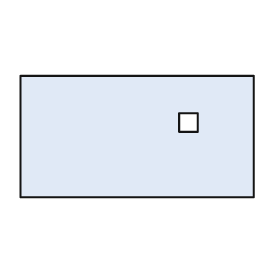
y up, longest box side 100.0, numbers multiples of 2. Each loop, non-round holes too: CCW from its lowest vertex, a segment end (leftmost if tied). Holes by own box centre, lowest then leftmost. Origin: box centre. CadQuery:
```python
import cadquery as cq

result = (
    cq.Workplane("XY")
    .moveTo(-50.0, -26.0)
    .lineTo(50.0, -26.0)
    .lineTo(50.0, 26.0)
    .lineTo(-50.0, 26.0)
    .close()
    .moveTo(18.0, 2.0)
    .lineTo(26.0, 2.0)
    .lineTo(26.0, 10.0)
    .lineTo(18.0, 10.0)
    .close()
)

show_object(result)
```